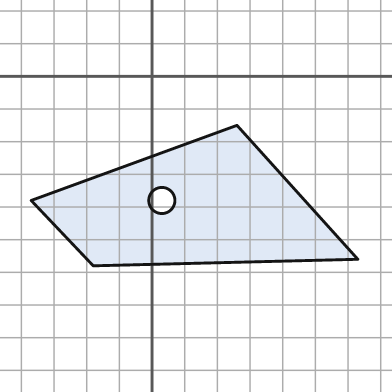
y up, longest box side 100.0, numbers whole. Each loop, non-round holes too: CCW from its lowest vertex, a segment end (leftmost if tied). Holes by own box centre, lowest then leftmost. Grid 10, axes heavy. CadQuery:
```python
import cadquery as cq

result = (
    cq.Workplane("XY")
    .moveTo(-18.0, -58.0)
    .lineTo(63.0, -56.0)
    .lineTo(26.0, -15.0)
    .lineTo(-37.0, -38.0)
    .close()
    .moveTo(3.0, -38.0)
    .circle(4.0)
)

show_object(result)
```